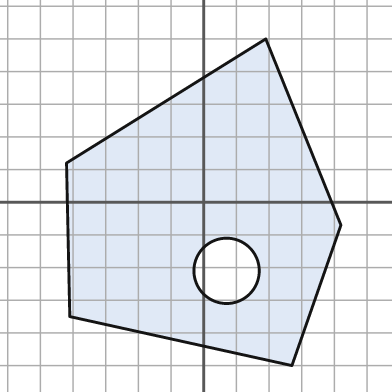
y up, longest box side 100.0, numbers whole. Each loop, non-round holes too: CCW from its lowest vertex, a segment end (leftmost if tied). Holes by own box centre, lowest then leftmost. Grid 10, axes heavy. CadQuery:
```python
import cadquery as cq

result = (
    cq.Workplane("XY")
    .moveTo(27.0, -50.0)
    .lineTo(42.0, -7.0)
    .lineTo(19.0, 50.0)
    .lineTo(-42.0, 12.0)
    .lineTo(-41.0, -35.0)
    .close()
    .moveTo(7.0, -21.0)
    .circle(10.0)
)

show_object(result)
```